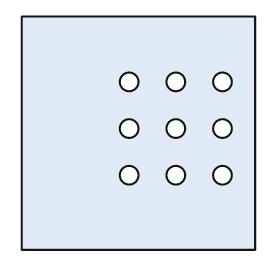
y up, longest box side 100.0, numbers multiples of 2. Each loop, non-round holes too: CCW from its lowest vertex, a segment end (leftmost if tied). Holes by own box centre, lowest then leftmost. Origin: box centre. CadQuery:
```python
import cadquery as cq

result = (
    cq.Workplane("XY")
    .moveTo(-50.0, -50.0)
    .lineTo(50.0, -50.0)
    .lineTo(50.0, 50.0)
    .lineTo(-50.0, 50.0)
    .close()
    .moveTo(-4.0, -18.0)
    .circle(4.0)
    .moveTo(16.0, -18.0)
    .circle(4.0)
    .moveTo(36.0, -18.0)
    .circle(4.0)
    .moveTo(-4.0, 2.0)
    .circle(4.0)
    .moveTo(16.0, 2.0)
    .circle(4.0)
    .moveTo(36.0, 2.0)
    .circle(4.0)
    .moveTo(-4.0, 22.0)
    .circle(4.0)
    .moveTo(16.0, 22.0)
    .circle(4.0)
    .moveTo(36.0, 22.0)
    .circle(4.0)
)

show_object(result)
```